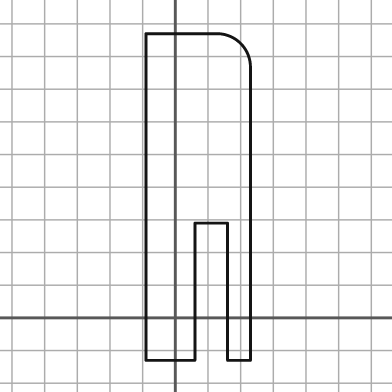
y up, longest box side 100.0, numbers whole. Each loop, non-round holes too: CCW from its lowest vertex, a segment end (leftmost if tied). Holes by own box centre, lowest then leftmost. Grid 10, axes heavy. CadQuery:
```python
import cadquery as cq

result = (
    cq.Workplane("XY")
    .moveTo(-9.0, -13.0)
    .lineTo(6.0, -13.0)
    .lineTo(6.0, 29.0)
    .lineTo(16.0, 29.0)
    .lineTo(16.0, -13.0)
    .lineTo(23.0, -13.0)
    .lineTo(23.0, 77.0)
    .threePointArc((20.0, 84.0), (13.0, 87.0))
    .lineTo(-9.0, 87.0)
    .close()
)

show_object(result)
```